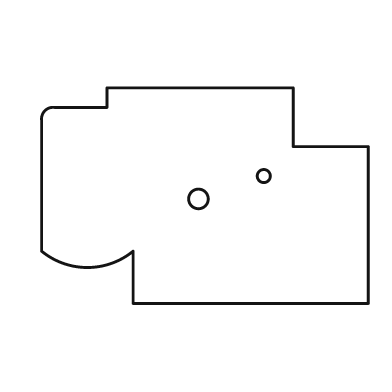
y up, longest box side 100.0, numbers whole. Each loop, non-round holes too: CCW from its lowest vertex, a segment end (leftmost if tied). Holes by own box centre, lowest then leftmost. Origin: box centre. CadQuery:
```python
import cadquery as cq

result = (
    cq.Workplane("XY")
    .moveTo(-22.0, -33.0)
    .lineTo(50.0, -33.0)
    .lineTo(50.0, 15.0)
    .lineTo(27.0, 15.0)
    .lineTo(27.0, 33.0)
    .lineTo(-30.0, 33.0)
    .lineTo(-30.0, 27.0)
    .lineTo(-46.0, 27.0)
    .threePointArc((-49.0, 26.0), (-50.0, 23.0))
    .lineTo(-50.0, -17.0)
    .threePointArc((-36.0, -22.0), (-22.0, -17.0))
    .close()
    .moveTo(-2.0, -1.0)
    .circle(3.0)
    .moveTo(18.0, 6.0)
    .circle(2.0)
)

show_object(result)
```